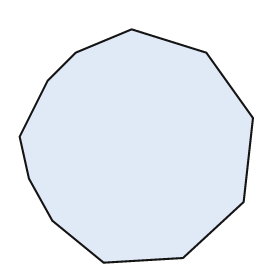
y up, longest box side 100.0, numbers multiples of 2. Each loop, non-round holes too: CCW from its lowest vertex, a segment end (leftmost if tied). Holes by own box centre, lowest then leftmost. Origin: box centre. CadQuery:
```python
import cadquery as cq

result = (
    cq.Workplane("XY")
    .moveTo(-14.0, -50.0)
    .lineTo(20.0, -48.0)
    .lineTo(46.0, -24.0)
    .lineTo(50.0, 12.0)
    .lineTo(30.0, 40.0)
    .lineTo(-2.0, 50.0)
    .lineTo(-26.0, 40.0)
    .lineTo(-38.0, 28.0)
    .lineTo(-50.0, 4.0)
    .lineTo(-46.0, -14.0)
    .lineTo(-36.0, -32.0)
    .close()
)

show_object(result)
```